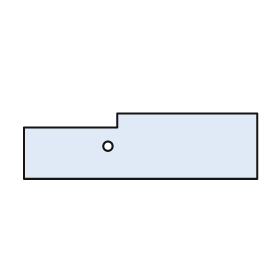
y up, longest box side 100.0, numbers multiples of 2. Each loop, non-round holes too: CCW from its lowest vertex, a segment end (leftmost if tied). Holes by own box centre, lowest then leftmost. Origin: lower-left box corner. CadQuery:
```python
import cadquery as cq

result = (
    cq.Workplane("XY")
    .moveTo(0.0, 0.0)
    .lineTo(100.0, 0.0)
    .lineTo(100.0, 28.0)
    .lineTo(40.0, 28.0)
    .lineTo(40.0, 22.0)
    .lineTo(0.0, 22.0)
    .close()
    .moveTo(36.0, 14.0)
    .circle(2.0)
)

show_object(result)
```